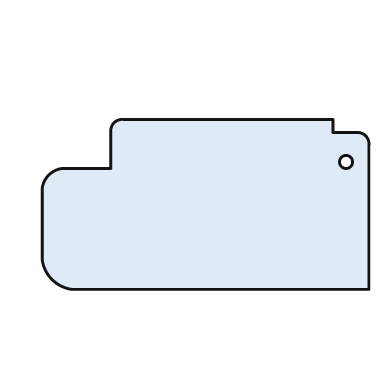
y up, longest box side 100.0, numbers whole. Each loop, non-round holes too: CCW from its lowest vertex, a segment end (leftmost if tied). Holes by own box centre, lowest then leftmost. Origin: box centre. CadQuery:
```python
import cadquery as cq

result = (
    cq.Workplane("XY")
    .moveTo(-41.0, -26.0)
    .lineTo(50.0, -26.0)
    .lineTo(50.0, 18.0)
    .threePointArc((49.0, 21.0), (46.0, 22.0))
    .lineTo(39.0, 22.0)
    .lineTo(39.0, 26.0)
    .lineTo(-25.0, 26.0)
    .threePointArc((-28.0, 25.0), (-29.0, 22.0))
    .lineTo(-29.0, 11.0)
    .lineTo(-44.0, 11.0)
    .threePointArc((-48.0, 9.0), (-50.0, 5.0))
    .lineTo(-50.0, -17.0)
    .threePointArc((-47.0, -23.0), (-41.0, -26.0))
    .close()
    .moveTo(43.0, 13.0)
    .circle(2.0)
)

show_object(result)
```